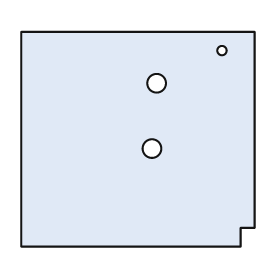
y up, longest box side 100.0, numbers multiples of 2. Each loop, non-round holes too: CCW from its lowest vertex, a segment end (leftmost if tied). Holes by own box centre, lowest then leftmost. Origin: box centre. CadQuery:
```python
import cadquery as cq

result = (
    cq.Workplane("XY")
    .moveTo(-50.0, -46.0)
    .lineTo(44.0, -46.0)
    .lineTo(44.0, -38.0)
    .lineTo(50.0, -38.0)
    .lineTo(50.0, 46.0)
    .lineTo(-50.0, 46.0)
    .close()
    .moveTo(6.0, -4.0)
    .circle(4.0)
    .moveTo(8.0, 24.0)
    .circle(4.0)
    .moveTo(36.0, 38.0)
    .circle(2.0)
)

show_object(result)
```